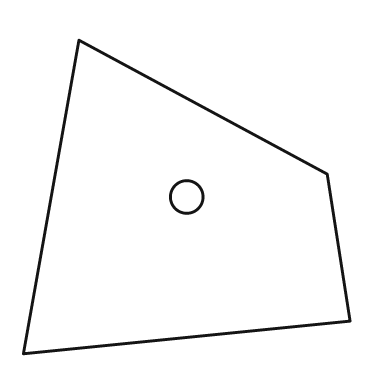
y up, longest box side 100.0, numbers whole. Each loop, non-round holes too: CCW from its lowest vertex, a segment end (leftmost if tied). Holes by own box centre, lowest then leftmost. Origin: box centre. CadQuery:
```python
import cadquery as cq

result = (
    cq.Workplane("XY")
    .moveTo(-50.0, -48.0)
    .lineTo(50.0, -38.0)
    .lineTo(43.0, 7.0)
    .lineTo(-33.0, 48.0)
    .close()
    .moveTo(0.0, 0.0)
    .circle(5.0)
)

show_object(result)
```